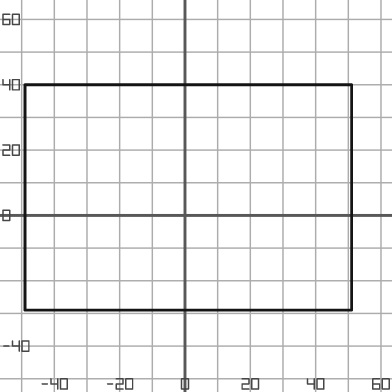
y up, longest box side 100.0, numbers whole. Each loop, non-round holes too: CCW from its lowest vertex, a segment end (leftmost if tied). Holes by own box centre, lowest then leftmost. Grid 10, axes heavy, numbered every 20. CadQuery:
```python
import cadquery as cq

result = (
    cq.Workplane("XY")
    .moveTo(-49.0, -29.0)
    .lineTo(51.0, -29.0)
    .lineTo(51.0, 40.0)
    .lineTo(-49.0, 40.0)
    .close()
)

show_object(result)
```